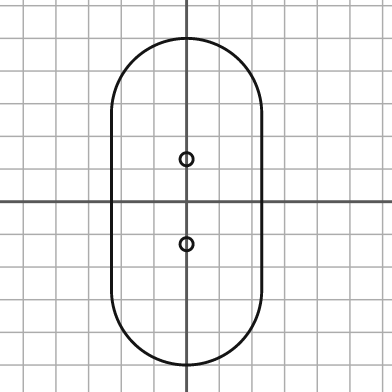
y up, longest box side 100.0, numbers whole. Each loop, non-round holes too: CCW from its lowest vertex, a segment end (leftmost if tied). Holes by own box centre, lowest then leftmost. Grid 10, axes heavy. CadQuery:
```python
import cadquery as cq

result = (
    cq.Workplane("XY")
    .moveTo(-23.0, -27.0)
    .threePointArc((0.0, -50.0), (23.0, -27.0))
    .lineTo(23.0, 27.0)
    .threePointArc((0.0, 50.0), (-23.0, 27.0))
    .close()
    .moveTo(0.0, -13.0)
    .circle(2.0)
    .moveTo(0.0, 13.0)
    .circle(2.0)
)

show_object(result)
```